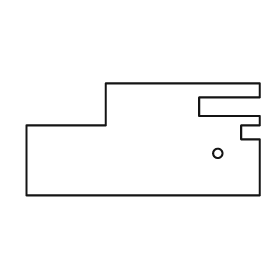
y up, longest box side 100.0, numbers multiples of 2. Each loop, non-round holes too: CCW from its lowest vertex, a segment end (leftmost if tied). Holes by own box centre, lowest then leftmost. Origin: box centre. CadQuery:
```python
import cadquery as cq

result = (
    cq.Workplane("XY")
    .moveTo(-50.0, -24.0)
    .lineTo(50.0, -24.0)
    .lineTo(50.0, 0.0)
    .lineTo(42.0, 0.0)
    .lineTo(42.0, 6.0)
    .lineTo(50.0, 6.0)
    .lineTo(50.0, 10.0)
    .lineTo(24.0, 10.0)
    .lineTo(24.0, 18.0)
    .lineTo(50.0, 18.0)
    .lineTo(50.0, 24.0)
    .lineTo(-16.0, 24.0)
    .lineTo(-16.0, 6.0)
    .lineTo(-50.0, 6.0)
    .close()
    .moveTo(32.0, -6.0)
    .circle(2.0)
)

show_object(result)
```